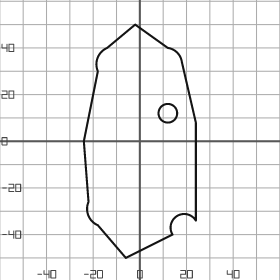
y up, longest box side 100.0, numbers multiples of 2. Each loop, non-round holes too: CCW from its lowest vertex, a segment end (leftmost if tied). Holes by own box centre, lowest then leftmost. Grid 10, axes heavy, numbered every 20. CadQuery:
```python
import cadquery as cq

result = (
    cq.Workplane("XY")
    .moveTo(-6.0, -50.0)
    .lineTo(14.0, -40.0)
    .threePointArc((16.0, -32.0), (24.0, -34.0))
    .lineTo(24.0, 8.0)
    .lineTo(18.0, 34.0)
    .threePointArc((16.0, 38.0), (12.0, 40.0))
    .lineTo(-2.0, 50.0)
    .lineTo(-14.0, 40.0)
    .threePointArc((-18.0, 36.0), (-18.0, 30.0))
    .lineTo(-24.0, 0.0)
    .lineTo(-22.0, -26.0)
    .threePointArc((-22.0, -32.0), (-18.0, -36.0))
    .close()
    .moveTo(12.0, 12.0)
    .circle(4.0)
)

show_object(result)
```